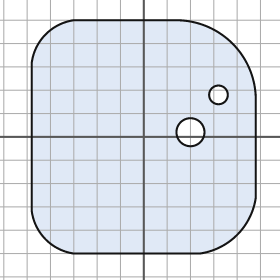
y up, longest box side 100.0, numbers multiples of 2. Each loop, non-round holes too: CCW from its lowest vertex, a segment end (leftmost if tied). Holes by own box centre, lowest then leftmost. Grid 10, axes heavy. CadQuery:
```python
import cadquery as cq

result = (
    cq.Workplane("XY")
    .moveTo(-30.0, -50.0)
    .lineTo(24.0, -50.0)
    .threePointArc((40.0, -42.0), (48.0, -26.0))
    .lineTo(48.0, 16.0)
    .threePointArc((38.0, 40.0), (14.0, 50.0))
    .lineTo(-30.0, 50.0)
    .threePointArc((-42.0, 44.0), (-48.0, 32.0))
    .lineTo(-48.0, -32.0)
    .threePointArc((-42.0, -44.0), (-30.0, -50.0))
    .close()
    .moveTo(20.0, 2.0)
    .circle(6.0)
    .moveTo(32.0, 18.0)
    .circle(4.0)
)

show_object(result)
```